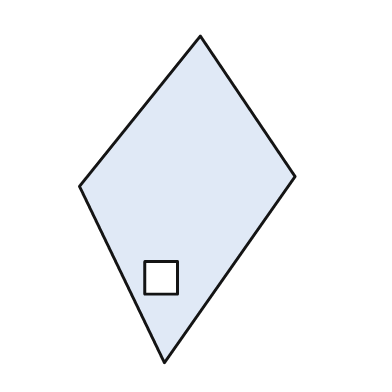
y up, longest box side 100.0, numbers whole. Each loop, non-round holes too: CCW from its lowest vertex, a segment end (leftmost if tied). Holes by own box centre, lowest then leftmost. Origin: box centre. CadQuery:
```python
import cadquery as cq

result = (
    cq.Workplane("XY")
    .moveTo(-7.0, -50.0)
    .lineTo(33.0, 7.0)
    .lineTo(4.0, 50.0)
    .lineTo(-33.0, 4.0)
    .close()
    .moveTo(-13.0, -29.0)
    .lineTo(-3.0, -29.0)
    .lineTo(-3.0, -19.0)
    .lineTo(-13.0, -19.0)
    .close()
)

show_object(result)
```